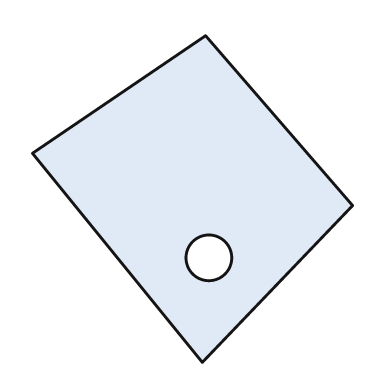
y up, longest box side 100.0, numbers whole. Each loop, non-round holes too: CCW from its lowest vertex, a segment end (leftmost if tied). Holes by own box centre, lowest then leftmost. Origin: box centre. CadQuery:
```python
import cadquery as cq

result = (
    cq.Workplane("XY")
    .moveTo(3.0, -50.0)
    .lineTo(49.0, -2.0)
    .lineTo(4.0, 50.0)
    .lineTo(-49.0, 14.0)
    .close()
    .moveTo(5.0, -18.0)
    .circle(7.0)
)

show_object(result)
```